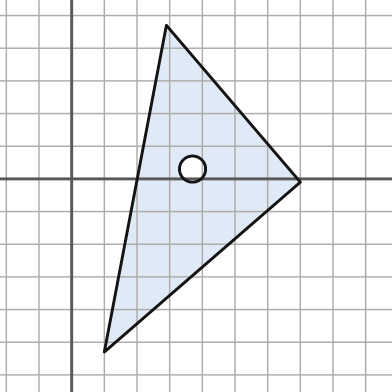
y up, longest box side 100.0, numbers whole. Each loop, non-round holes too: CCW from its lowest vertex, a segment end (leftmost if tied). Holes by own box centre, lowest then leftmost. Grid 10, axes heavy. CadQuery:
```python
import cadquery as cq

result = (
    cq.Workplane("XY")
    .moveTo(10.0, -53.0)
    .lineTo(70.0, -1.0)
    .lineTo(29.0, 47.0)
    .close()
    .moveTo(37.0, 3.0)
    .circle(4.0)
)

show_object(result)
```